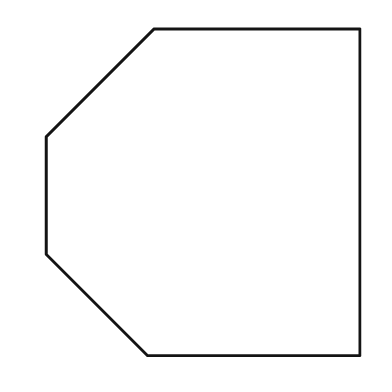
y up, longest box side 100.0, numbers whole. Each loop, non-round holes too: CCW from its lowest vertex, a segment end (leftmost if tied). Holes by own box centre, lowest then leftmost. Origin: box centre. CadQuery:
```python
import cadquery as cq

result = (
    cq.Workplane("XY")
    .moveTo(-17.0, -50.0)
    .lineTo(48.0, -50.0)
    .lineTo(48.0, 50.0)
    .lineTo(-15.0, 50.0)
    .lineTo(-48.0, 17.0)
    .lineTo(-48.0, -19.0)
    .close()
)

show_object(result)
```